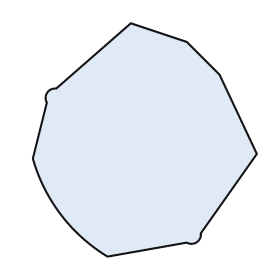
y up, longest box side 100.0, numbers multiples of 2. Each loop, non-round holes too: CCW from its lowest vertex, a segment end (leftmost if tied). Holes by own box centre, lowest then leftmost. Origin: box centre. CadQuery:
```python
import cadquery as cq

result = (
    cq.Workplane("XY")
    .moveTo(-16.0, -50.0)
    .lineTo(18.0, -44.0)
    .threePointArc((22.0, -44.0), (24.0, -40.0))
    .lineTo(48.0, -6.0)
    .lineTo(32.0, 28.0)
    .lineTo(18.0, 42.0)
    .lineTo(-6.0, 50.0)
    .lineTo(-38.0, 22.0)
    .threePointArc((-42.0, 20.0), (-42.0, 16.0))
    .lineTo(-48.0, -8.0)
    .threePointArc((-36.0, -32.0), (-16.0, -50.0))
    .close()
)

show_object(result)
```